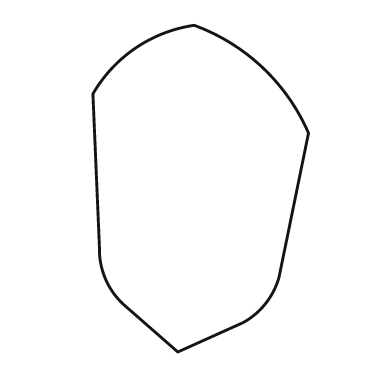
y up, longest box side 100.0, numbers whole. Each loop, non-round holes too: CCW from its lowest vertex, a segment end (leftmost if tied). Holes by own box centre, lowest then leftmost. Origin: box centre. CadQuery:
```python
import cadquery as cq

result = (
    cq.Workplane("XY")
    .moveTo(-7.0, -50.0)
    .lineTo(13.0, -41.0)
    .threePointArc((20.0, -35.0), (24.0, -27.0))
    .lineTo(33.0, 17.0)
    .threePointArc((19.0, 37.0), (-2.0, 50.0))
    .threePointArc((-20.0, 43.0), (-33.0, 29.0))
    .lineTo(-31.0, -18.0)
    .threePointArc((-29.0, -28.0), (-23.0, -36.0))
    .close()
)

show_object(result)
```